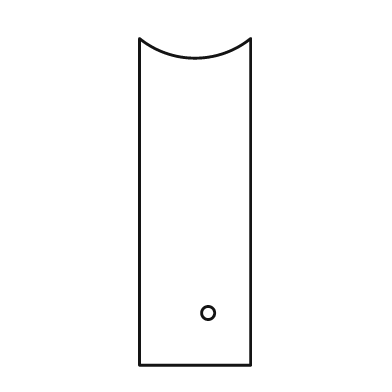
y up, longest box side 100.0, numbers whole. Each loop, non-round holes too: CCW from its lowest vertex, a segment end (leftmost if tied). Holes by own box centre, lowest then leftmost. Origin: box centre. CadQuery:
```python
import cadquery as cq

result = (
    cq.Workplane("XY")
    .moveTo(-17.0, -50.0)
    .lineTo(17.0, -50.0)
    .lineTo(17.0, 50.0)
    .threePointArc((0.0, 44.0), (-17.0, 50.0))
    .close()
    .moveTo(4.0, -34.0)
    .circle(2.0)
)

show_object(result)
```